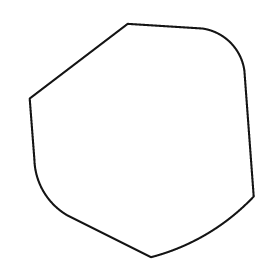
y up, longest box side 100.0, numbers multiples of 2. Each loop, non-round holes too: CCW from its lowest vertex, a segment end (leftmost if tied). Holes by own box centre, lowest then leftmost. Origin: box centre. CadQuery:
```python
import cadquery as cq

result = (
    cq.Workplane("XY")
    .moveTo(4.0, -50.0)
    .threePointArc((28.0, -40.0), (48.0, -24.0))
    .lineTo(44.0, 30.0)
    .threePointArc((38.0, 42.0), (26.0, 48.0))
    .lineTo(-6.0, 50.0)
    .lineTo(-48.0, 18.0)
    .lineTo(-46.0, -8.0)
    .threePointArc((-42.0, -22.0), (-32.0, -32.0))
    .close()
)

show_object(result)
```